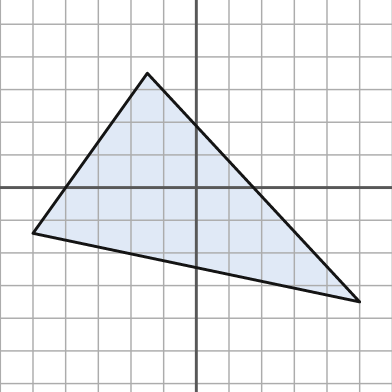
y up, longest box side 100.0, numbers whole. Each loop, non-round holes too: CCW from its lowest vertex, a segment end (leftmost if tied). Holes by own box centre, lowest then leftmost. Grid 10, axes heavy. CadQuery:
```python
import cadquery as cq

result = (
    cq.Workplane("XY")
    .moveTo(50.0, -35.0)
    .lineTo(-15.0, 35.0)
    .lineTo(-50.0, -14.0)
    .close()
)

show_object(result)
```